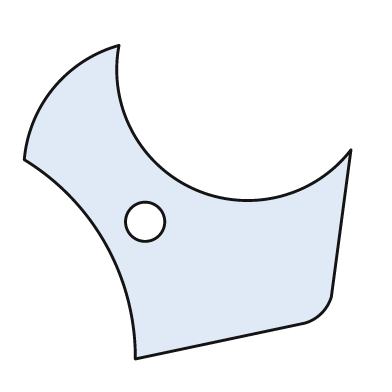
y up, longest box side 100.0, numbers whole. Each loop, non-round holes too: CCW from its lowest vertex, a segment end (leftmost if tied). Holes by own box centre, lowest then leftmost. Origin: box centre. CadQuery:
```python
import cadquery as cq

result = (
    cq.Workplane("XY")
    .moveTo(-16.0, -48.0)
    .lineTo(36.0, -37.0)
    .threePointArc((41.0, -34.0), (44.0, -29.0))
    .lineTo(50.0, 16.0)
    .threePointArc((2.0, 4.0), (-21.0, 48.0))
    .threePointArc((-41.0, 35.0), (-50.0, 13.0))
    .threePointArc((-25.0, -13.0), (-16.0, -48.0))
    .close()
    .moveTo(-13.0, -6.0)
    .circle(6.0)
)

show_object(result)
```